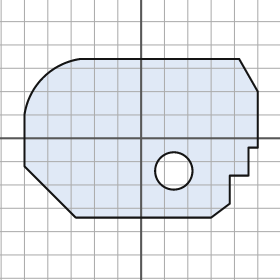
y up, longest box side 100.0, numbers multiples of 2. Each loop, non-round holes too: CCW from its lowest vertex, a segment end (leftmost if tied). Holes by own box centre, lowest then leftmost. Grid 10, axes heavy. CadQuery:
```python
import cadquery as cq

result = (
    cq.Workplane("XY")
    .moveTo(-28.0, -34.0)
    .lineTo(30.0, -34.0)
    .lineTo(38.0, -28.0)
    .lineTo(38.0, -16.0)
    .lineTo(46.0, -16.0)
    .lineTo(46.0, -4.0)
    .lineTo(50.0, -4.0)
    .lineTo(50.0, 20.0)
    .lineTo(42.0, 34.0)
    .lineTo(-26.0, 34.0)
    .threePointArc((-42.0, 26.0), (-50.0, 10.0))
    .lineTo(-50.0, -12.0)
    .close()
    .moveTo(14.0, -14.0)
    .circle(8.0)
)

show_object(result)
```